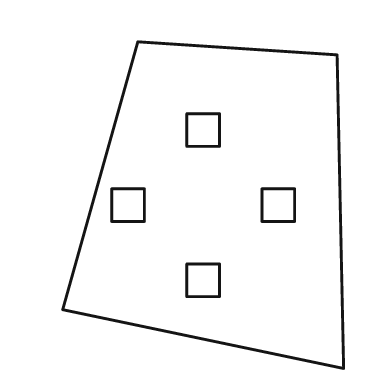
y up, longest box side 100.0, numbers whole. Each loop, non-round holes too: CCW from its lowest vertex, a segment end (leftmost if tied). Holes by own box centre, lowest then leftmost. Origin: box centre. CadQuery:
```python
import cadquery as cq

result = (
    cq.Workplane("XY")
    .moveTo(43.0, -50.0)
    .lineTo(41.0, 46.0)
    .lineTo(-20.0, 50.0)
    .lineTo(-43.0, -32.0)
    .close()
    .moveTo(-5.0, -28.0)
    .lineTo(5.0, -28.0)
    .lineTo(5.0, -18.0)
    .lineTo(-5.0, -18.0)
    .close()
    .moveTo(-28.0, -5.0)
    .lineTo(-18.0, -5.0)
    .lineTo(-18.0, 5.0)
    .lineTo(-28.0, 5.0)
    .close()
    .moveTo(18.0, -5.0)
    .lineTo(28.0, -5.0)
    .lineTo(28.0, 5.0)
    .lineTo(18.0, 5.0)
    .close()
    .moveTo(-5.0, 18.0)
    .lineTo(5.0, 18.0)
    .lineTo(5.0, 28.0)
    .lineTo(-5.0, 28.0)
    .close()
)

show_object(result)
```